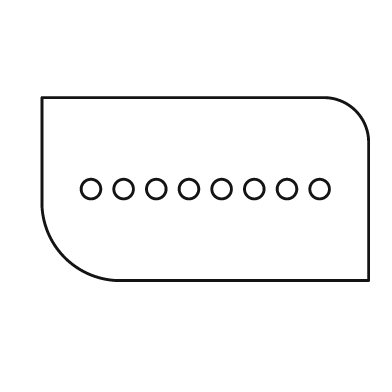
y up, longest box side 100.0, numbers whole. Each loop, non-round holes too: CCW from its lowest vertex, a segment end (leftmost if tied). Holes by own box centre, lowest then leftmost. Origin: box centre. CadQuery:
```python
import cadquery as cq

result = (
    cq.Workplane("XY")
    .moveTo(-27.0, -28.0)
    .lineTo(50.0, -28.0)
    .lineTo(50.0, 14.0)
    .threePointArc((46.0, 24.0), (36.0, 28.0))
    .lineTo(-50.0, 28.0)
    .lineTo(-50.0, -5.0)
    .threePointArc((-43.0, -21.0), (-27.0, -28.0))
    .close()
    .moveTo(-35.0, 0.0)
    .circle(3.0)
    .moveTo(-25.0, 0.0)
    .circle(3.0)
    .moveTo(-15.0, 0.0)
    .circle(3.0)
    .moveTo(-5.0, 0.0)
    .circle(3.0)
    .moveTo(5.0, 0.0)
    .circle(3.0)
    .moveTo(15.0, 0.0)
    .circle(3.0)
    .moveTo(25.0, 0.0)
    .circle(3.0)
    .moveTo(35.0, 0.0)
    .circle(3.0)
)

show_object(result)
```